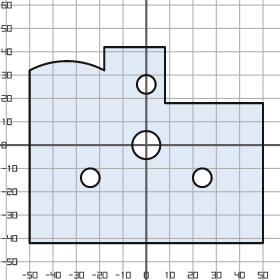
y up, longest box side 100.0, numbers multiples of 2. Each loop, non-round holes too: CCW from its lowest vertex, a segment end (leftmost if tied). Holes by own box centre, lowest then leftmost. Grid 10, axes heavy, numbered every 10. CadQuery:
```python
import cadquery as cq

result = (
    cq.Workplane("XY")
    .moveTo(-50.0, -42.0)
    .lineTo(50.0, -42.0)
    .lineTo(50.0, 18.0)
    .lineTo(8.0, 18.0)
    .lineTo(8.0, 42.0)
    .lineTo(-18.0, 42.0)
    .lineTo(-18.0, 32.0)
    .threePointArc((-34.0, 36.0), (-50.0, 32.0))
    .close()
    .moveTo(-24.0, -14.0)
    .circle(4.0)
    .moveTo(24.0, -14.0)
    .circle(4.0)
    .moveTo(0.0, 0.0)
    .circle(6.0)
    .moveTo(0.0, 26.0)
    .circle(4.0)
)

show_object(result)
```